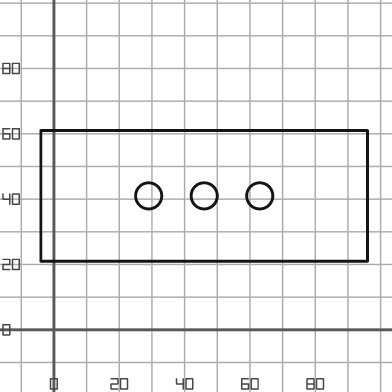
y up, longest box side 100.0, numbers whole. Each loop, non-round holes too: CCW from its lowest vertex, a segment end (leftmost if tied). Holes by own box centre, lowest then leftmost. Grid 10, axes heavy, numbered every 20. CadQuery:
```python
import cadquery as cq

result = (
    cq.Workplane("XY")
    .moveTo(-4.0, 21.0)
    .lineTo(96.0, 21.0)
    .lineTo(96.0, 61.0)
    .lineTo(-4.0, 61.0)
    .close()
    .moveTo(29.0, 41.0)
    .circle(4.0)
    .moveTo(46.0, 41.0)
    .circle(4.0)
    .moveTo(63.0, 41.0)
    .circle(4.0)
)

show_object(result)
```